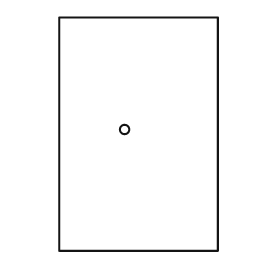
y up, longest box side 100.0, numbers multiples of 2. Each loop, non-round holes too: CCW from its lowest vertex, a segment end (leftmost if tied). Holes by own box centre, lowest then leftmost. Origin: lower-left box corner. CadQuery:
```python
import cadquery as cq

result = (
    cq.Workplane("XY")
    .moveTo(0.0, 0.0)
    .lineTo(68.0, 0.0)
    .lineTo(68.0, 100.0)
    .lineTo(0.0, 100.0)
    .close()
    .moveTo(28.0, 52.0)
    .circle(2.0)
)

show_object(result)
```